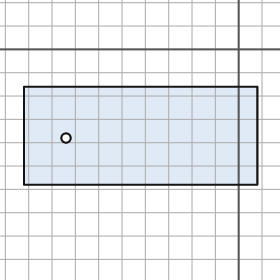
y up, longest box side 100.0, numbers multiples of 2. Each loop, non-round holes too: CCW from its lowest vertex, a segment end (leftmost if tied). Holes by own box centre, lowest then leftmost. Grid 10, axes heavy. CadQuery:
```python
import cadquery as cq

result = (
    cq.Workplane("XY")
    .moveTo(-92.0, -58.0)
    .lineTo(8.0, -58.0)
    .lineTo(8.0, -16.0)
    .lineTo(-92.0, -16.0)
    .close()
    .moveTo(-74.0, -38.0)
    .circle(2.0)
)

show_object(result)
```